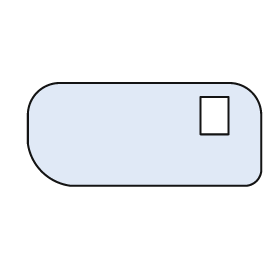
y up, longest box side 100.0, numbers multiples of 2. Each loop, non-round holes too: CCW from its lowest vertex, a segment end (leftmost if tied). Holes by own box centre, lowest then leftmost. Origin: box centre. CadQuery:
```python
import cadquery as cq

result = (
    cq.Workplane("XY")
    .moveTo(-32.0, -22.0)
    .lineTo(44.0, -22.0)
    .threePointArc((48.0, -20.0), (50.0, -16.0))
    .lineTo(50.0, 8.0)
    .threePointArc((46.0, 18.0), (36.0, 22.0))
    .lineTo(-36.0, 22.0)
    .threePointArc((-46.0, 18.0), (-50.0, 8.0))
    .lineTo(-50.0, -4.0)
    .threePointArc((-44.0, -16.0), (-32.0, -22.0))
    .close()
    .moveTo(24.0, 0.0)
    .lineTo(36.0, 0.0)
    .lineTo(36.0, 16.0)
    .lineTo(24.0, 16.0)
    .close()
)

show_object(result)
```